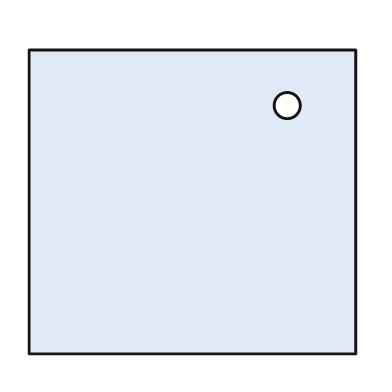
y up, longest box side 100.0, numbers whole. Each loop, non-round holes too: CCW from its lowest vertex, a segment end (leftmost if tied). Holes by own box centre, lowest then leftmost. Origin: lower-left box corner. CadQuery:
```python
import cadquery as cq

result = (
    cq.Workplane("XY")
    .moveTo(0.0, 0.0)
    .lineTo(100.0, 0.0)
    .lineTo(100.0, 93.0)
    .lineTo(0.0, 93.0)
    .close()
    .moveTo(79.0, 76.0)
    .circle(4.0)
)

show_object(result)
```